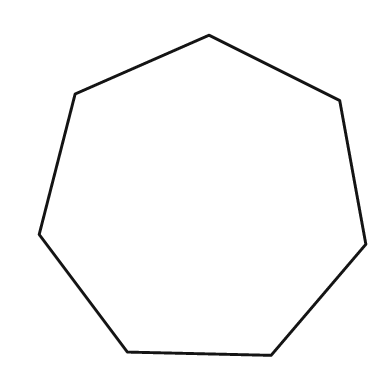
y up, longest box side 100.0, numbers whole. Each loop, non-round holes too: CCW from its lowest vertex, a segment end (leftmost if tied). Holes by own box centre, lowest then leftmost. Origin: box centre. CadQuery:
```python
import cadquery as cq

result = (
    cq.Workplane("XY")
    .moveTo(21.0, -49.0)
    .lineTo(50.0, -15.0)
    .lineTo(42.0, 29.0)
    .lineTo(2.0, 49.0)
    .lineTo(-39.0, 31.0)
    .lineTo(-50.0, -12.0)
    .lineTo(-23.0, -48.0)
    .close()
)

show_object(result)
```